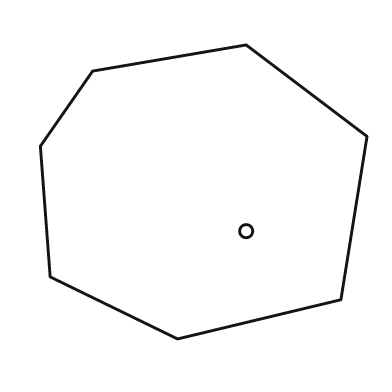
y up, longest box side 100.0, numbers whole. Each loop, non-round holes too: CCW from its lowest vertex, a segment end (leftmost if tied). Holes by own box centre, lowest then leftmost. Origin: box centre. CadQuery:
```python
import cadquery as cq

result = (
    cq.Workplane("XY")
    .moveTo(-8.0, -45.0)
    .lineTo(42.0, -33.0)
    .lineTo(50.0, 17.0)
    .lineTo(13.0, 45.0)
    .lineTo(-34.0, 37.0)
    .lineTo(-50.0, 14.0)
    .lineTo(-47.0, -26.0)
    .close()
    .moveTo(13.0, -12.0)
    .circle(2.0)
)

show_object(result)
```